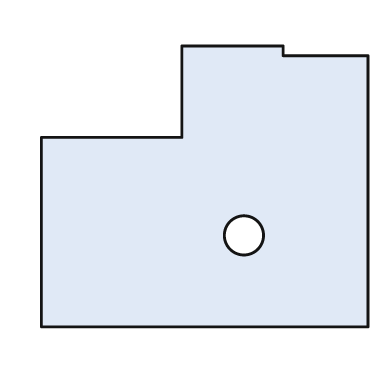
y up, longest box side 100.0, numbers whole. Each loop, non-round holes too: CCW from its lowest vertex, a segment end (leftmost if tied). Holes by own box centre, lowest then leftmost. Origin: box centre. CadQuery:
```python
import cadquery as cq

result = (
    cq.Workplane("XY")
    .moveTo(-50.0, -43.0)
    .lineTo(50.0, -43.0)
    .lineTo(50.0, 40.0)
    .lineTo(24.0, 40.0)
    .lineTo(24.0, 43.0)
    .lineTo(-7.0, 43.0)
    .lineTo(-7.0, 15.0)
    .lineTo(-50.0, 15.0)
    .close()
    .moveTo(12.0, -15.0)
    .circle(6.0)
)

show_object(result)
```